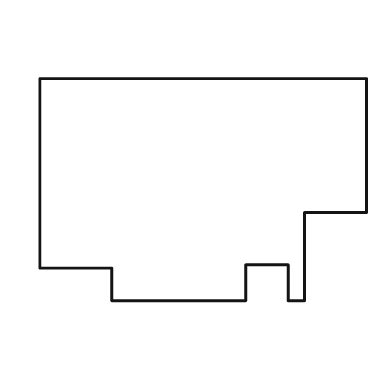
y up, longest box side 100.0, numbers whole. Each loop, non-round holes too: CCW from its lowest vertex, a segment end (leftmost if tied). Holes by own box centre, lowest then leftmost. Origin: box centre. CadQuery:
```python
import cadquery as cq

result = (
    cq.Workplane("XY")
    .moveTo(-28.0, -34.0)
    .lineTo(13.0, -34.0)
    .lineTo(13.0, -23.0)
    .lineTo(26.0, -23.0)
    .lineTo(26.0, -34.0)
    .lineTo(31.0, -34.0)
    .lineTo(31.0, -7.0)
    .lineTo(50.0, -7.0)
    .lineTo(50.0, 34.0)
    .lineTo(-50.0, 34.0)
    .lineTo(-50.0, -24.0)
    .lineTo(-28.0, -24.0)
    .close()
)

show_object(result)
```